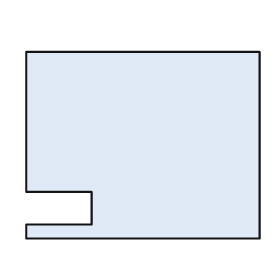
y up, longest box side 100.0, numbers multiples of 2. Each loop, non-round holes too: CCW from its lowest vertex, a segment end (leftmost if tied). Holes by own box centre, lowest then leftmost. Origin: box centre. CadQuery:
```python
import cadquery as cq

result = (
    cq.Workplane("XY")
    .moveTo(-50.0, -40.0)
    .lineTo(50.0, -40.0)
    .lineTo(50.0, 40.0)
    .lineTo(-50.0, 40.0)
    .lineTo(-50.0, -20.0)
    .lineTo(-22.0, -20.0)
    .lineTo(-22.0, -34.0)
    .lineTo(-50.0, -34.0)
    .close()
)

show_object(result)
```